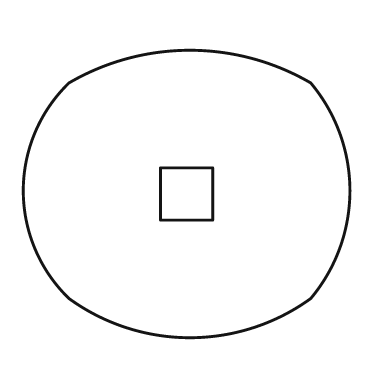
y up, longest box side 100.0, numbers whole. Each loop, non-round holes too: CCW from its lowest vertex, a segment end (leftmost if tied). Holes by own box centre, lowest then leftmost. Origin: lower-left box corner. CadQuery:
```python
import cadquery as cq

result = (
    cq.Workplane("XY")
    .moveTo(14.0, 12.0)
    .threePointArc((51.0, 0.0), (88.0, 12.0))
    .threePointArc((100.0, 45.0), (88.0, 78.0))
    .threePointArc((51.0, 88.0), (14.0, 78.0))
    .threePointArc((0.0, 45.0), (14.0, 12.0))
    .close()
    .moveTo(42.0, 36.0)
    .lineTo(58.0, 36.0)
    .lineTo(58.0, 52.0)
    .lineTo(42.0, 52.0)
    .close()
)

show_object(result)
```